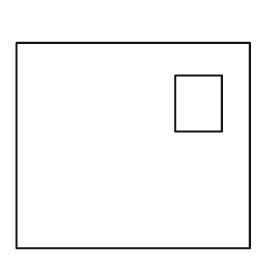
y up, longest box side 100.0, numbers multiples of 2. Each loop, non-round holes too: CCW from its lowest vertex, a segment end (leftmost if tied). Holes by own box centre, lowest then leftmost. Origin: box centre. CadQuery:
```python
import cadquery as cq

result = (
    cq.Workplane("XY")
    .moveTo(-50.0, -44.0)
    .lineTo(50.0, -44.0)
    .lineTo(50.0, 44.0)
    .lineTo(-50.0, 44.0)
    .close()
    .moveTo(18.0, 6.0)
    .lineTo(38.0, 6.0)
    .lineTo(38.0, 30.0)
    .lineTo(18.0, 30.0)
    .close()
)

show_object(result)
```